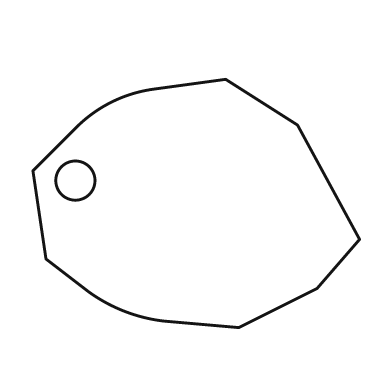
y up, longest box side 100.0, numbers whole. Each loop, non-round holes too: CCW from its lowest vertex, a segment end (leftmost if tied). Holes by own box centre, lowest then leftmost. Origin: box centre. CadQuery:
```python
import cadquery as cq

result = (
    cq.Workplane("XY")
    .moveTo(13.0, -38.0)
    .lineTo(37.0, -26.0)
    .lineTo(50.0, -11.0)
    .lineTo(31.0, 24.0)
    .lineTo(9.0, 38.0)
    .lineTo(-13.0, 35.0)
    .threePointArc((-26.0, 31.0), (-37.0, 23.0))
    .lineTo(-50.0, 10.0)
    .lineTo(-46.0, -17.0)
    .lineTo(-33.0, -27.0)
    .threePointArc((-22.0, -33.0), (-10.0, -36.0))
    .close()
    .moveTo(-37.0, 7.0)
    .circle(6.0)
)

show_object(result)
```